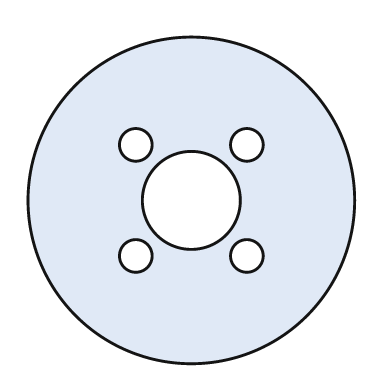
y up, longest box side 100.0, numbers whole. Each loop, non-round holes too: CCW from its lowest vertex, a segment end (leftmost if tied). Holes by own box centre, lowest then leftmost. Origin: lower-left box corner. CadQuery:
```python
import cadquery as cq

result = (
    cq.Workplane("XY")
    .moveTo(50.0, 50.0)
    .circle(50.0)
    .moveTo(33.0, 33.0)
    .circle(5.0)
    .moveTo(67.0, 33.0)
    .circle(5.0)
    .moveTo(50.0, 50.0)
    .circle(15.0)
    .moveTo(33.0, 67.0)
    .circle(5.0)
    .moveTo(67.0, 67.0)
    .circle(5.0)
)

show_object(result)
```